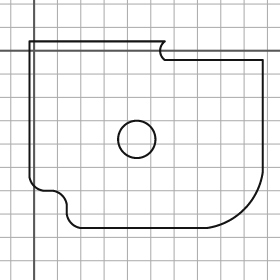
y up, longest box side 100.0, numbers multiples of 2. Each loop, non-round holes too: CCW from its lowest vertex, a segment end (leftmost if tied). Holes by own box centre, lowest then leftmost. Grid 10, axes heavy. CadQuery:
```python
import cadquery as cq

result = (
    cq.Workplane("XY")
    .moveTo(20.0, -76.0)
    .lineTo(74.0, -76.0)
    .threePointArc((90.0, -68.0), (98.0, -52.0))
    .lineTo(98.0, -4.0)
    .lineTo(56.0, -4.0)
    .threePointArc((54.0, 0.0), (56.0, 4.0))
    .lineTo(-2.0, 4.0)
    .lineTo(-2.0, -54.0)
    .threePointArc((0.0, -58.0), (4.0, -60.0))
    .lineTo(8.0, -60.0)
    .threePointArc((12.0, -62.0), (14.0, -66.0))
    .lineTo(14.0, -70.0)
    .threePointArc((16.0, -74.0), (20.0, -76.0))
    .close()
    .moveTo(44.0, -38.0)
    .circle(8.0)
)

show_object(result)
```